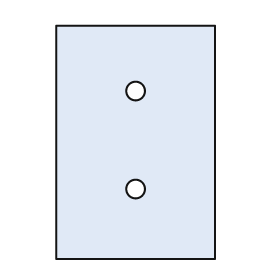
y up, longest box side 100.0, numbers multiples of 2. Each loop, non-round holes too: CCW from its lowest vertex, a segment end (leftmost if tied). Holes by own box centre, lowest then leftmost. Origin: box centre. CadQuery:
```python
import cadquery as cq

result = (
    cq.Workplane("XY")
    .moveTo(-34.0, -50.0)
    .lineTo(34.0, -50.0)
    .lineTo(34.0, 50.0)
    .lineTo(-34.0, 50.0)
    .close()
    .moveTo(0.0, -20.0)
    .circle(4.0)
    .moveTo(0.0, 22.0)
    .circle(4.0)
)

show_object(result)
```